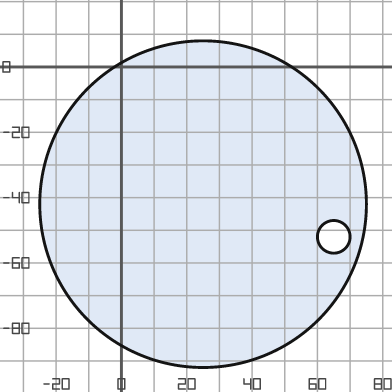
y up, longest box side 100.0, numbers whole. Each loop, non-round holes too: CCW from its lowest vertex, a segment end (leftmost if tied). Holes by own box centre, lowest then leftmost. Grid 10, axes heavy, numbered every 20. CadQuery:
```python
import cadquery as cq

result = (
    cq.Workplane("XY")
    .moveTo(25.0, -42.0)
    .circle(50.0)
    .moveTo(65.0, -52.0)
    .circle(5.0)
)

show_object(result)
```